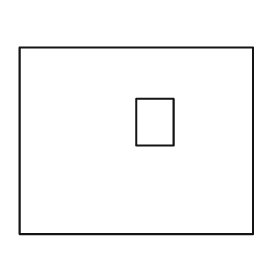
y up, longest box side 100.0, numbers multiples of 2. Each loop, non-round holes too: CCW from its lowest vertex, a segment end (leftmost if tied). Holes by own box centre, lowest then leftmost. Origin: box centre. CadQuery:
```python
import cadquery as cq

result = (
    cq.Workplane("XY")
    .moveTo(-50.0, -40.0)
    .lineTo(50.0, -40.0)
    .lineTo(50.0, 40.0)
    .lineTo(-50.0, 40.0)
    .close()
    .moveTo(0.0, -2.0)
    .lineTo(16.0, -2.0)
    .lineTo(16.0, 18.0)
    .lineTo(0.0, 18.0)
    .close()
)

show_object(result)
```